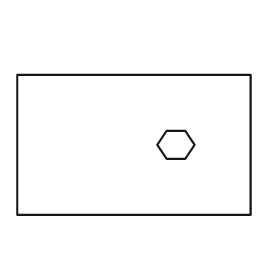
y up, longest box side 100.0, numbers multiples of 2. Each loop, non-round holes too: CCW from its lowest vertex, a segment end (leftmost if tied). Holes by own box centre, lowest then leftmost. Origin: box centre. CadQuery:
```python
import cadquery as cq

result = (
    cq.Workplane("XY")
    .moveTo(-50.0, -30.0)
    .lineTo(50.0, -30.0)
    .lineTo(50.0, 30.0)
    .lineTo(-50.0, 30.0)
    .close()
    .moveTo(14.0, -6.0)
    .lineTo(22.0, -6.0)
    .lineTo(26.0, 0.0)
    .lineTo(22.0, 6.0)
    .lineTo(14.0, 6.0)
    .lineTo(10.0, 0.0)
    .close()
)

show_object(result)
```